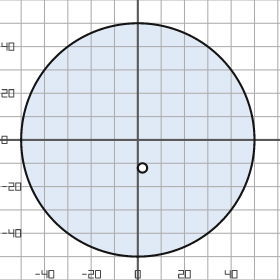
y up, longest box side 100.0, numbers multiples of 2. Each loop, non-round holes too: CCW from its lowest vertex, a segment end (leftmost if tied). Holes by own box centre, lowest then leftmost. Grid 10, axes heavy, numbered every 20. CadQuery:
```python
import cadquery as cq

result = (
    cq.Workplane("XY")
    .moveTo(0.0, 0.0)
    .circle(50.0)
    .moveTo(2.0, -12.0)
    .circle(2.0)
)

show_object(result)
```